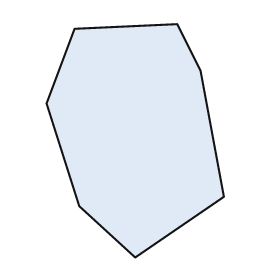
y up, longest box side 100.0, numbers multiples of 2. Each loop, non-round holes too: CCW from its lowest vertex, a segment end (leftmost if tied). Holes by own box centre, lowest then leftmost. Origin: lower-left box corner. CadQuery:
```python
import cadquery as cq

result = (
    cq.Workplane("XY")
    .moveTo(38.0, 0.0)
    .lineTo(76.0, 26.0)
    .lineTo(66.0, 80.0)
    .lineTo(56.0, 100.0)
    .lineTo(12.0, 98.0)
    .lineTo(0.0, 66.0)
    .lineTo(14.0, 22.0)
    .close()
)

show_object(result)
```